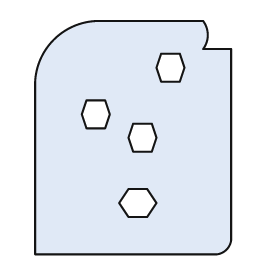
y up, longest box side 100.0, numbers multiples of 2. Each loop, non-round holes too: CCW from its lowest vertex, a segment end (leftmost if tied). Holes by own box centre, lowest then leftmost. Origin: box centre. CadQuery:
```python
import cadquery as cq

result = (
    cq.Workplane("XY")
    .moveTo(-42.0, -50.0)
    .lineTo(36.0, -50.0)
    .threePointArc((40.0, -48.0), (42.0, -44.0))
    .lineTo(42.0, 38.0)
    .lineTo(30.0, 38.0)
    .threePointArc((32.0, 44.0), (30.0, 50.0))
    .lineTo(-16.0, 50.0)
    .threePointArc((-34.0, 42.0), (-42.0, 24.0))
    .close()
    .moveTo(-2.0, -34.0)
    .lineTo(6.0, -34.0)
    .lineTo(10.0, -28.0)
    .lineTo(6.0, -22.0)
    .lineTo(-2.0, -22.0)
    .lineTo(-6.0, -28.0)
    .close()
    .moveTo(0.0, -6.0)
    .lineTo(8.0, -6.0)
    .lineTo(10.0, 0.0)
    .lineTo(8.0, 6.0)
    .lineTo(0.0, 6.0)
    .lineTo(-2.0, 0.0)
    .close()
    .moveTo(-20.0, 4.0)
    .lineTo(-12.0, 4.0)
    .lineTo(-10.0, 10.0)
    .lineTo(-12.0, 16.0)
    .lineTo(-20.0, 16.0)
    .lineTo(-22.0, 10.0)
    .close()
    .moveTo(12.0, 24.0)
    .lineTo(20.0, 24.0)
    .lineTo(22.0, 30.0)
    .lineTo(20.0, 36.0)
    .lineTo(12.0, 36.0)
    .lineTo(10.0, 30.0)
    .close()
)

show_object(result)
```